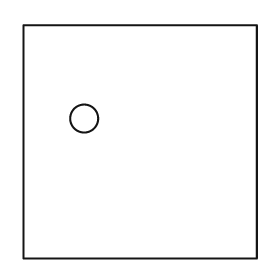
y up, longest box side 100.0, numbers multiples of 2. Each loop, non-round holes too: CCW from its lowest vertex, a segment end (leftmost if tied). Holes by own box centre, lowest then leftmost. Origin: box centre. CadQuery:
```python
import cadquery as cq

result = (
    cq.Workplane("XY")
    .moveTo(-50.0, -50.0)
    .lineTo(50.0, -50.0)
    .lineTo(50.0, 50.0)
    .lineTo(-50.0, 50.0)
    .close()
    .moveTo(-24.0, 10.0)
    .circle(6.0)
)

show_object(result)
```